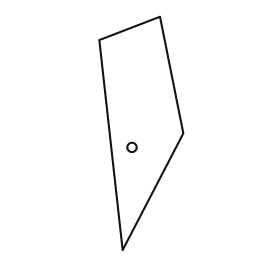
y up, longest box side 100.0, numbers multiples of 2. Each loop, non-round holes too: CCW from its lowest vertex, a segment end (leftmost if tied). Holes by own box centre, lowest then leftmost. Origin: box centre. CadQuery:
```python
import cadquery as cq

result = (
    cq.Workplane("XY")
    .moveTo(-8.0, -50.0)
    .lineTo(18.0, 0.0)
    .lineTo(8.0, 50.0)
    .lineTo(-18.0, 40.0)
    .close()
    .moveTo(-4.0, -6.0)
    .circle(2.0)
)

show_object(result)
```